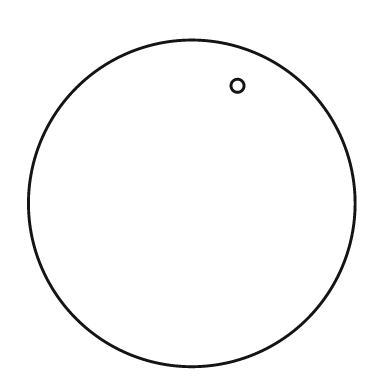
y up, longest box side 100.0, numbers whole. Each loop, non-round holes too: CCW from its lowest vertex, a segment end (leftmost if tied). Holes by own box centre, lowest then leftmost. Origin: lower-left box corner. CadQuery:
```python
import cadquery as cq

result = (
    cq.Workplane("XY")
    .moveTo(50.0, 50.0)
    .circle(50.0)
    .moveTo(64.0, 86.0)
    .circle(2.0)
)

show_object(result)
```